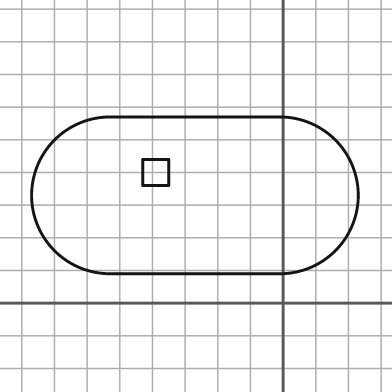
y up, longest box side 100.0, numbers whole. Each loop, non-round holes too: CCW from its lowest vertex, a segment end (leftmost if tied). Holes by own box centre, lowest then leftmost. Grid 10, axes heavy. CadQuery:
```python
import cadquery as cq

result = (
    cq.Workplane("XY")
    .moveTo(-53.0, 9.0)
    .lineTo(-1.0, 9.0)
    .threePointArc((23.0, 33.0), (-1.0, 57.0))
    .lineTo(-53.0, 57.0)
    .threePointArc((-77.0, 33.0), (-53.0, 9.0))
    .close()
    .moveTo(-43.0, 36.0)
    .lineTo(-35.0, 36.0)
    .lineTo(-35.0, 44.0)
    .lineTo(-43.0, 44.0)
    .close()
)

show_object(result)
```